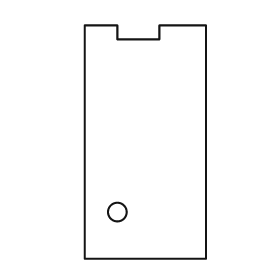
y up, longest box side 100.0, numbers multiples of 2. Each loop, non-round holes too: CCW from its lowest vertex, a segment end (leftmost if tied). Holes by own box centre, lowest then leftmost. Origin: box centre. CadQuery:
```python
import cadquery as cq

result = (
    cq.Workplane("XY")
    .moveTo(-26.0, -50.0)
    .lineTo(26.0, -50.0)
    .lineTo(26.0, 50.0)
    .lineTo(6.0, 50.0)
    .lineTo(6.0, 44.0)
    .lineTo(-12.0, 44.0)
    .lineTo(-12.0, 50.0)
    .lineTo(-26.0, 50.0)
    .close()
    .moveTo(-12.0, -30.0)
    .circle(4.0)
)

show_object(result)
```